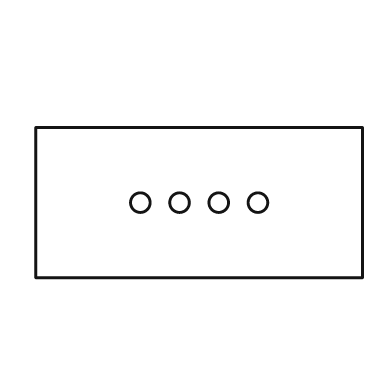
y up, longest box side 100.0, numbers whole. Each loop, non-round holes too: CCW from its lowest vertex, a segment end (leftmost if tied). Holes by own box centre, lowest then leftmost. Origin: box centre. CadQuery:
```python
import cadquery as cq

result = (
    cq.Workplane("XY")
    .moveTo(-50.0, -23.0)
    .lineTo(50.0, -23.0)
    .lineTo(50.0, 23.0)
    .lineTo(-50.0, 23.0)
    .close()
    .moveTo(-18.0, 0.0)
    .circle(3.0)
    .moveTo(-6.0, 0.0)
    .circle(3.0)
    .moveTo(6.0, 0.0)
    .circle(3.0)
    .moveTo(18.0, 0.0)
    .circle(3.0)
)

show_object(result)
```